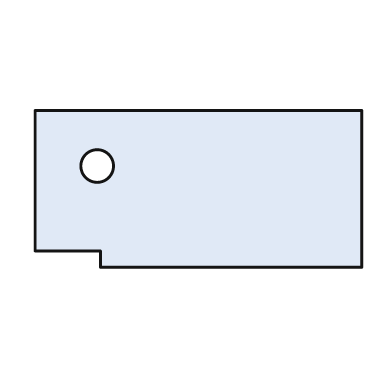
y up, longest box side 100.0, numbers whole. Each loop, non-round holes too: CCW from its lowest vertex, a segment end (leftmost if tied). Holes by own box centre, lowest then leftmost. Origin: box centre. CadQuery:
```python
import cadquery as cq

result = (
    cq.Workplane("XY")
    .moveTo(-30.0, -24.0)
    .lineTo(50.0, -24.0)
    .lineTo(50.0, 24.0)
    .lineTo(-50.0, 24.0)
    .lineTo(-50.0, -19.0)
    .lineTo(-30.0, -19.0)
    .close()
    .moveTo(-31.0, 7.0)
    .circle(5.0)
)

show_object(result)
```